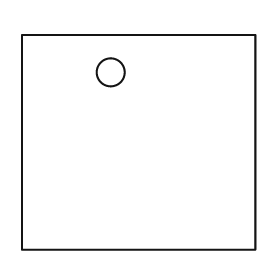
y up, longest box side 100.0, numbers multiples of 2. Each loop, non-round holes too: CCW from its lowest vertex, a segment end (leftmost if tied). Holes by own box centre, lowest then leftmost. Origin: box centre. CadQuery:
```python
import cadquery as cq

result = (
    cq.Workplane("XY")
    .moveTo(-50.0, -46.0)
    .lineTo(50.0, -46.0)
    .lineTo(50.0, 46.0)
    .lineTo(-50.0, 46.0)
    .close()
    .moveTo(-12.0, 30.0)
    .circle(6.0)
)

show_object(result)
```